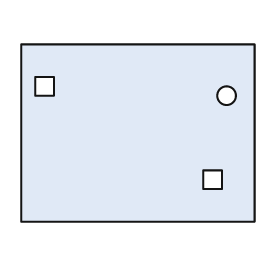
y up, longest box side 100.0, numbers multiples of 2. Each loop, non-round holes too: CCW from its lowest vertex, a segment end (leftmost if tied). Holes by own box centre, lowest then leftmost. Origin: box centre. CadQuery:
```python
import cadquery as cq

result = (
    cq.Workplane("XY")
    .moveTo(-50.0, -38.0)
    .lineTo(50.0, -38.0)
    .lineTo(50.0, 38.0)
    .lineTo(-50.0, 38.0)
    .close()
    .moveTo(28.0, -24.0)
    .lineTo(36.0, -24.0)
    .lineTo(36.0, -16.0)
    .lineTo(28.0, -16.0)
    .close()
    .moveTo(38.0, 16.0)
    .circle(4.0)
    .moveTo(-44.0, 16.0)
    .lineTo(-36.0, 16.0)
    .lineTo(-36.0, 24.0)
    .lineTo(-44.0, 24.0)
    .close()
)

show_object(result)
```